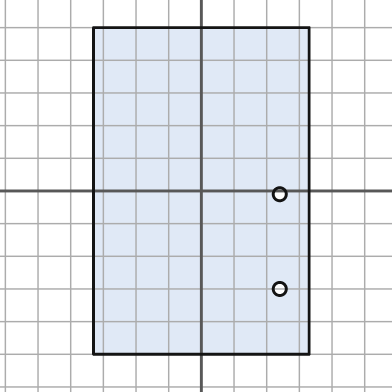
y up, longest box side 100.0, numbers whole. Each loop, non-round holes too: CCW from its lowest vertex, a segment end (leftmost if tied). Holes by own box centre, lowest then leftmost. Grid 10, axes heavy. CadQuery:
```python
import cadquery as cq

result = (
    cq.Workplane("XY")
    .moveTo(-33.0, -50.0)
    .lineTo(33.0, -50.0)
    .lineTo(33.0, 50.0)
    .lineTo(-33.0, 50.0)
    .close()
    .moveTo(24.0, -30.0)
    .circle(2.0)
    .moveTo(24.0, -1.0)
    .circle(2.0)
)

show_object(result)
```